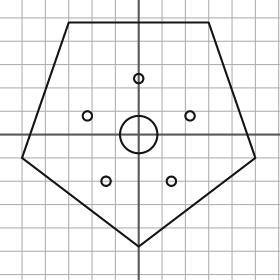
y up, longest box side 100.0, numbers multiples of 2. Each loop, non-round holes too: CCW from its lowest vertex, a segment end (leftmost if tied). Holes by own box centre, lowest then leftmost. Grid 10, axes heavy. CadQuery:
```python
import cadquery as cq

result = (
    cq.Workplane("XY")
    .moveTo(0.0, -48.0)
    .lineTo(50.0, -10.0)
    .lineTo(30.0, 48.0)
    .lineTo(-30.0, 48.0)
    .lineTo(-50.0, -10.0)
    .close()
    .moveTo(-14.0, -20.0)
    .circle(2.0)
    .moveTo(14.0, -20.0)
    .circle(2.0)
    .moveTo(0.0, 0.0)
    .circle(8.0)
    .moveTo(-22.0, 8.0)
    .circle(2.0)
    .moveTo(22.0, 8.0)
    .circle(2.0)
    .moveTo(0.0, 24.0)
    .circle(2.0)
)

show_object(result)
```